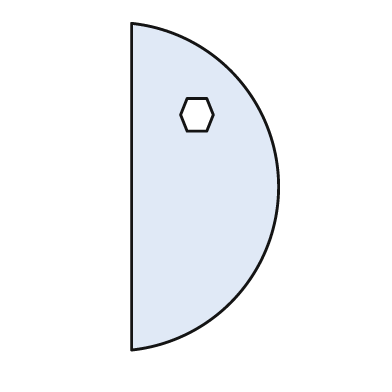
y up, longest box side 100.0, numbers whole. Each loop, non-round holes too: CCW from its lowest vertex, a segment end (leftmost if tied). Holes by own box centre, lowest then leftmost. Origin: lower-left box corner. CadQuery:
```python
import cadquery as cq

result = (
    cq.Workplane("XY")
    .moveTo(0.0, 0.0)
    .threePointArc((45.0, 50.0), (0.0, 100.0))
    .close()
    .moveTo(17.0, 67.0)
    .lineTo(23.0, 67.0)
    .lineTo(25.0, 72.0)
    .lineTo(23.0, 77.0)
    .lineTo(17.0, 77.0)
    .lineTo(15.0, 72.0)
    .close()
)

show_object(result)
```